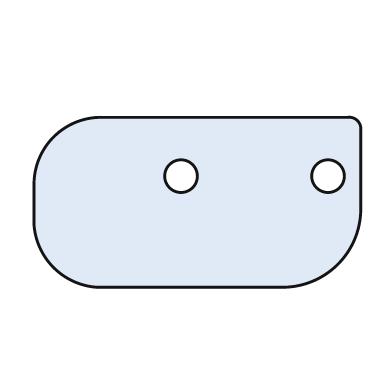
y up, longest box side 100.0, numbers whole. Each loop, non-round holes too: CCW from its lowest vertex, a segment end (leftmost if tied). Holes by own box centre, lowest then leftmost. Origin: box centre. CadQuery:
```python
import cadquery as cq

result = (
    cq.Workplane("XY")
    .moveTo(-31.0, -26.0)
    .lineTo(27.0, -26.0)
    .threePointArc((43.0, -19.0), (50.0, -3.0))
    .lineTo(50.0, 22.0)
    .threePointArc((49.0, 25.0), (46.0, 26.0))
    .lineTo(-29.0, 26.0)
    .threePointArc((-44.0, 20.0), (-50.0, 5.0))
    .lineTo(-50.0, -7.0)
    .threePointArc((-44.0, -20.0), (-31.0, -26.0))
    .close()
    .moveTo(-5.0, 8.0)
    .circle(5.0)
    .moveTo(40.0, 8.0)
    .circle(5.0)
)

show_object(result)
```